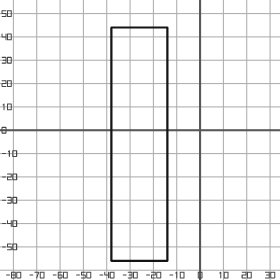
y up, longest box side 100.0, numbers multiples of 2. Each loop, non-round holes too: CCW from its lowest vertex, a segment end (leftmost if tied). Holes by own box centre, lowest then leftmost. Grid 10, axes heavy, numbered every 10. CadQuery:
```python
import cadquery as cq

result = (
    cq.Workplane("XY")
    .moveTo(-38.0, -56.0)
    .lineTo(-14.0, -56.0)
    .lineTo(-14.0, 44.0)
    .lineTo(-38.0, 44.0)
    .close()
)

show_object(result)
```